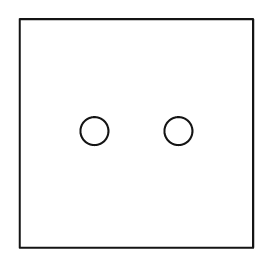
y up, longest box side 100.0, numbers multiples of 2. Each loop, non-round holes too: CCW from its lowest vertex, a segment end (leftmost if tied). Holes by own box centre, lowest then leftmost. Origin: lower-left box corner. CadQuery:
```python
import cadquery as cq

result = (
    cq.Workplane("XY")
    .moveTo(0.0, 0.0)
    .lineTo(100.0, 0.0)
    .lineTo(100.0, 98.0)
    .lineTo(0.0, 98.0)
    .close()
    .moveTo(32.0, 50.0)
    .circle(6.0)
    .moveTo(68.0, 50.0)
    .circle(6.0)
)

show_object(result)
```